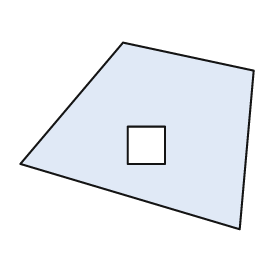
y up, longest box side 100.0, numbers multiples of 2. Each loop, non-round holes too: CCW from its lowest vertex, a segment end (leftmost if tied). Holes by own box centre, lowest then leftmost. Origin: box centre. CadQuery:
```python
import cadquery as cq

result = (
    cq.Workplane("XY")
    .moveTo(44.0, -40.0)
    .lineTo(50.0, 28.0)
    .lineTo(-6.0, 40.0)
    .lineTo(-50.0, -12.0)
    .close()
    .moveTo(-4.0, -12.0)
    .lineTo(12.0, -12.0)
    .lineTo(12.0, 4.0)
    .lineTo(-4.0, 4.0)
    .close()
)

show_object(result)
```